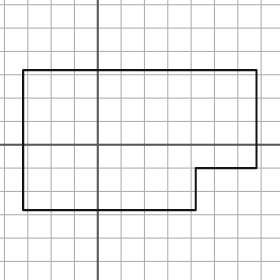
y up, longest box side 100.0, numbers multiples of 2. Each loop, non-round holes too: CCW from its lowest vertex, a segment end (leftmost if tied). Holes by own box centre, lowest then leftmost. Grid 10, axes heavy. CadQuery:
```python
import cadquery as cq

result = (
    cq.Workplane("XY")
    .moveTo(-32.0, -28.0)
    .lineTo(42.0, -28.0)
    .lineTo(42.0, -10.0)
    .lineTo(68.0, -10.0)
    .lineTo(68.0, 32.0)
    .lineTo(-32.0, 32.0)
    .close()
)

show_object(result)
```